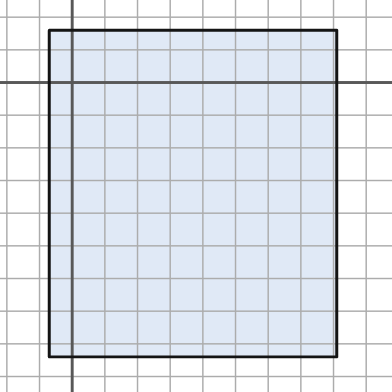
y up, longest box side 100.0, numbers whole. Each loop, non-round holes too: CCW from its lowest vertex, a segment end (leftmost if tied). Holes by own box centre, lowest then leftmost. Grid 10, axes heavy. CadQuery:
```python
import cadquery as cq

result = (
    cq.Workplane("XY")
    .moveTo(-7.0, -84.0)
    .lineTo(81.0, -84.0)
    .lineTo(81.0, 16.0)
    .lineTo(-7.0, 16.0)
    .close()
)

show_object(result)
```